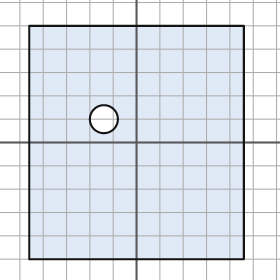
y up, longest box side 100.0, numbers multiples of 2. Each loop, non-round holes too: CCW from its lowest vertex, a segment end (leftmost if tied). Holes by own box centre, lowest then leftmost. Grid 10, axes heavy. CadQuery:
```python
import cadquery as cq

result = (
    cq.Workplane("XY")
    .moveTo(-46.0, -50.0)
    .lineTo(46.0, -50.0)
    .lineTo(46.0, 50.0)
    .lineTo(-46.0, 50.0)
    .close()
    .moveTo(-14.0, 10.0)
    .circle(6.0)
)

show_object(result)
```